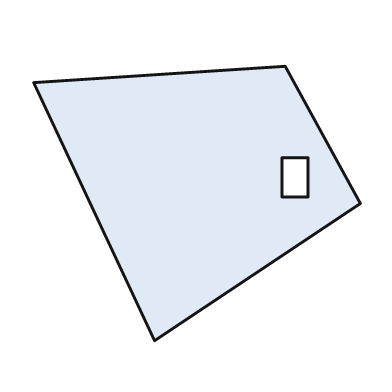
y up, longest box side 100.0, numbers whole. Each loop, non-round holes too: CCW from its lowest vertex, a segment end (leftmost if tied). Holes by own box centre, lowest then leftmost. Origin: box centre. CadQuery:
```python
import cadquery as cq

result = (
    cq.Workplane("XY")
    .moveTo(-13.0, -42.0)
    .lineTo(50.0, 0.0)
    .lineTo(27.0, 42.0)
    .lineTo(-50.0, 37.0)
    .close()
    .moveTo(26.0, 2.0)
    .lineTo(34.0, 2.0)
    .lineTo(34.0, 14.0)
    .lineTo(26.0, 14.0)
    .close()
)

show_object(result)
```